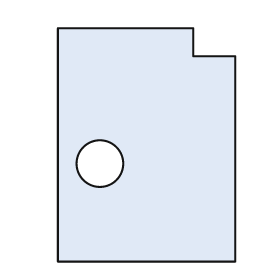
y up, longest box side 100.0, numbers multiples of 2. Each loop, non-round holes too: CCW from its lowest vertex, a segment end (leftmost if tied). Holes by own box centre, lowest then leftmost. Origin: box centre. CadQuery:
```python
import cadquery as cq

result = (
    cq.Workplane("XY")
    .moveTo(-38.0, -50.0)
    .lineTo(38.0, -50.0)
    .lineTo(38.0, 38.0)
    .lineTo(20.0, 38.0)
    .lineTo(20.0, 50.0)
    .lineTo(-38.0, 50.0)
    .close()
    .moveTo(-20.0, -8.0)
    .circle(10.0)
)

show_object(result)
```